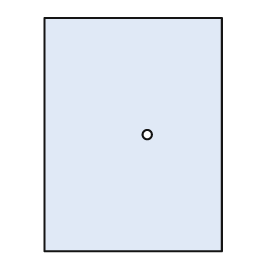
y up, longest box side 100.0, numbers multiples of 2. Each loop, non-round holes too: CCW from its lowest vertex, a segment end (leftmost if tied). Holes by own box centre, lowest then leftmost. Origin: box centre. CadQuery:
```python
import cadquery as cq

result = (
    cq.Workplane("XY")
    .moveTo(-38.0, -50.0)
    .lineTo(38.0, -50.0)
    .lineTo(38.0, 50.0)
    .lineTo(-38.0, 50.0)
    .close()
    .moveTo(6.0, 0.0)
    .circle(2.0)
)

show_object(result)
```